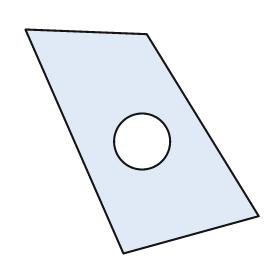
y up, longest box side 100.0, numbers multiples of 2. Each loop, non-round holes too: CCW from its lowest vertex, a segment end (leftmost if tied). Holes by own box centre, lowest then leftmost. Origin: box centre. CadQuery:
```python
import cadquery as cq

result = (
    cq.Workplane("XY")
    .moveTo(-8.0, -48.0)
    .lineTo(50.0, -32.0)
    .lineTo(2.0, 46.0)
    .lineTo(-50.0, 48.0)
    .close()
    .moveTo(0.0, 0.0)
    .circle(12.0)
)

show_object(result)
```